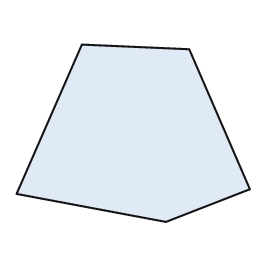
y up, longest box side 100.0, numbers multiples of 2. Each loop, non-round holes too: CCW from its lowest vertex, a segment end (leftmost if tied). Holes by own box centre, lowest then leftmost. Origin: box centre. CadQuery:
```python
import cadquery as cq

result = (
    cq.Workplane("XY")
    .moveTo(14.0, -38.0)
    .lineTo(50.0, -24.0)
    .lineTo(24.0, 36.0)
    .lineTo(-22.0, 38.0)
    .lineTo(-50.0, -26.0)
    .close()
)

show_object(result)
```